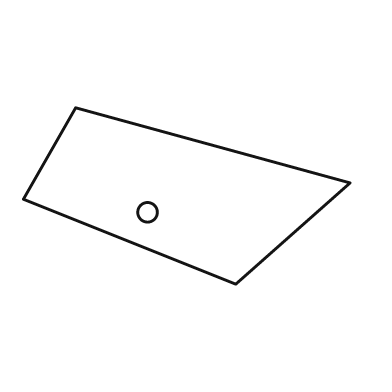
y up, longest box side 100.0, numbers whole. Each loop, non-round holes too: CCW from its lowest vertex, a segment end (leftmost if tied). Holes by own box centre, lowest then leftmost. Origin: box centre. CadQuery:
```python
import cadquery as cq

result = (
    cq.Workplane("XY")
    .moveTo(15.0, -27.0)
    .lineTo(50.0, 4.0)
    .lineTo(-34.0, 27.0)
    .lineTo(-50.0, -1.0)
    .close()
    .moveTo(-12.0, -5.0)
    .circle(3.0)
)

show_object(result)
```